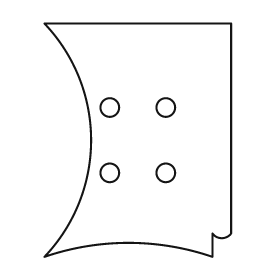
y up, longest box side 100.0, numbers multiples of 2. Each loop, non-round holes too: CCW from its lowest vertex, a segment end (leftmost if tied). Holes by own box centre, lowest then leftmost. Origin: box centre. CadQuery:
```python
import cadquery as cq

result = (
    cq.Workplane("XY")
    .moveTo(-40.0, -50.0)
    .threePointArc((-4.0, -44.0), (32.0, -50.0))
    .lineTo(32.0, -40.0)
    .threePointArc((36.0, -42.0), (40.0, -40.0))
    .lineTo(40.0, 50.0)
    .lineTo(-40.0, 50.0)
    .threePointArc((-20.0, 0.0), (-40.0, -50.0))
    .close()
    .moveTo(-12.0, -14.0)
    .circle(4.0)
    .moveTo(12.0, -14.0)
    .circle(4.0)
    .moveTo(-12.0, 14.0)
    .circle(4.0)
    .moveTo(12.0, 14.0)
    .circle(4.0)
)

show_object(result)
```